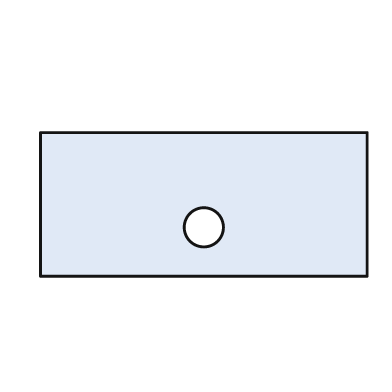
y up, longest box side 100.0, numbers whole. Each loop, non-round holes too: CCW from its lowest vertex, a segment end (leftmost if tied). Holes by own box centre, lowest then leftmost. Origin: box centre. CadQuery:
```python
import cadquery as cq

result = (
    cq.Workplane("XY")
    .moveTo(-50.0, -22.0)
    .lineTo(50.0, -22.0)
    .lineTo(50.0, 22.0)
    .lineTo(-50.0, 22.0)
    .close()
    .moveTo(0.0, -7.0)
    .circle(6.0)
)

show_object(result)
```